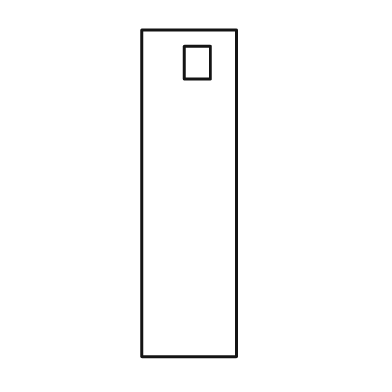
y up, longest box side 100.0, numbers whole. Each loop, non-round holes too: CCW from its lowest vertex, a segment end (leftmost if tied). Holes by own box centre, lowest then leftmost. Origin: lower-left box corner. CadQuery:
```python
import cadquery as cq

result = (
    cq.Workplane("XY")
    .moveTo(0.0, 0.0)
    .lineTo(29.0, 0.0)
    .lineTo(29.0, 100.0)
    .lineTo(0.0, 100.0)
    .close()
    .moveTo(13.0, 85.0)
    .lineTo(21.0, 85.0)
    .lineTo(21.0, 95.0)
    .lineTo(13.0, 95.0)
    .close()
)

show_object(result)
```